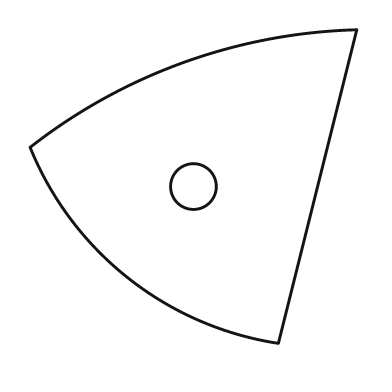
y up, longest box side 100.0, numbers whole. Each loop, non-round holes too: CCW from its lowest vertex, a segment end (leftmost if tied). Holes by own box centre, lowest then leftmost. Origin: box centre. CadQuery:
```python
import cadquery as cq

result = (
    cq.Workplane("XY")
    .moveTo(26.0, -48.0)
    .lineTo(50.0, 48.0)
    .threePointArc((-3.0, 38.0), (-50.0, 12.0))
    .threePointArc((-20.0, -28.0), (26.0, -48.0))
    .close()
    .moveTo(0.0, 0.0)
    .circle(7.0)
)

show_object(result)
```